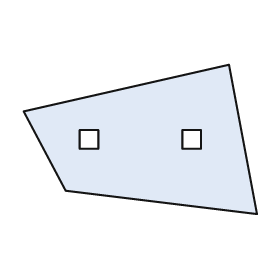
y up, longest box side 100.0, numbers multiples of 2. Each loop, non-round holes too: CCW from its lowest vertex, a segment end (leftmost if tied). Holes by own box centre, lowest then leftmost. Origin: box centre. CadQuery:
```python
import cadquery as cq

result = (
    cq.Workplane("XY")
    .moveTo(50.0, -32.0)
    .lineTo(38.0, 32.0)
    .lineTo(-50.0, 12.0)
    .lineTo(-32.0, -22.0)
    .close()
    .moveTo(-26.0, -4.0)
    .lineTo(-18.0, -4.0)
    .lineTo(-18.0, 4.0)
    .lineTo(-26.0, 4.0)
    .close()
    .moveTo(18.0, -4.0)
    .lineTo(26.0, -4.0)
    .lineTo(26.0, 4.0)
    .lineTo(18.0, 4.0)
    .close()
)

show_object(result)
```